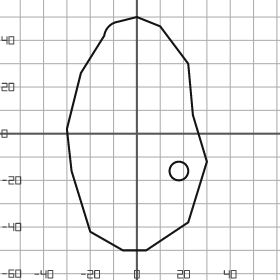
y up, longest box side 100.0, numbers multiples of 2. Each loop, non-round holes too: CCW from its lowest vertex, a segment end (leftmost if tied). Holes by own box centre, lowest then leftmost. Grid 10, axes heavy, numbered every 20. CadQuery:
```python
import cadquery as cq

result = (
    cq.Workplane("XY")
    .moveTo(-6.0, -50.0)
    .lineTo(4.0, -50.0)
    .lineTo(22.0, -38.0)
    .lineTo(30.0, -12.0)
    .lineTo(24.0, 8.0)
    .lineTo(22.0, 30.0)
    .lineTo(10.0, 46.0)
    .lineTo(0.0, 50.0)
    .lineTo(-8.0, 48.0)
    .threePointArc((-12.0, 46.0), (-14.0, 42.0))
    .lineTo(-24.0, 26.0)
    .lineTo(-30.0, 2.0)
    .lineTo(-28.0, -16.0)
    .lineTo(-20.0, -42.0)
    .close()
    .moveTo(18.0, -16.0)
    .circle(4.0)
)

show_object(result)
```